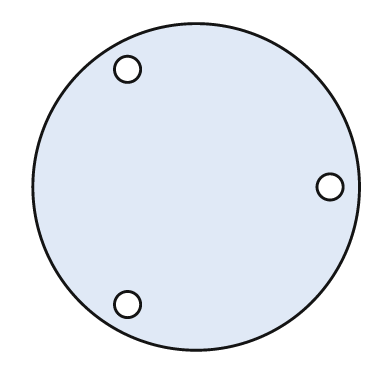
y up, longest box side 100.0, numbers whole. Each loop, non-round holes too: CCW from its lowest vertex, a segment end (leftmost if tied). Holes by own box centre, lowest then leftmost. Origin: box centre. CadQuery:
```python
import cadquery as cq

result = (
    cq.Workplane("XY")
    .moveTo(0.0, 0.0)
    .circle(50.0)
    .moveTo(-21.0, -36.0)
    .circle(4.0)
    .moveTo(41.0, 0.0)
    .circle(4.0)
    .moveTo(-21.0, 36.0)
    .circle(4.0)
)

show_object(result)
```